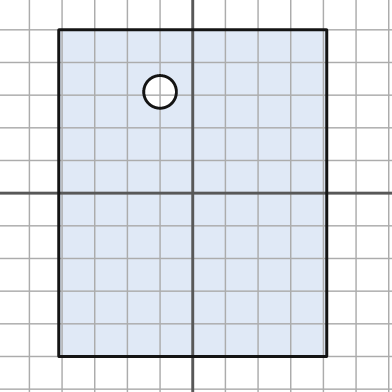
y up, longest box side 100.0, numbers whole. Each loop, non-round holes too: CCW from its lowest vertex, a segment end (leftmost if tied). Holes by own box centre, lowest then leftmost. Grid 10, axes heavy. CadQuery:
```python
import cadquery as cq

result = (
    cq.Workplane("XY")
    .moveTo(-41.0, -50.0)
    .lineTo(41.0, -50.0)
    .lineTo(41.0, 50.0)
    .lineTo(-41.0, 50.0)
    .close()
    .moveTo(-10.0, 31.0)
    .circle(5.0)
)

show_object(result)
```